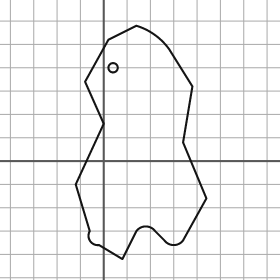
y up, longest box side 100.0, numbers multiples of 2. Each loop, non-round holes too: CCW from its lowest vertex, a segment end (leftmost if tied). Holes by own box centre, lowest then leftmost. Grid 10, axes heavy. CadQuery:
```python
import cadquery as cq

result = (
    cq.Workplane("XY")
    .moveTo(8.0, -42.0)
    .lineTo(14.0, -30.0)
    .threePointArc((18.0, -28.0), (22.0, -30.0))
    .lineTo(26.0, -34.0)
    .threePointArc((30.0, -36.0), (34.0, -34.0))
    .lineTo(44.0, -16.0)
    .lineTo(34.0, 8.0)
    .lineTo(38.0, 32.0)
    .lineTo(28.0, 48.0)
    .threePointArc((22.0, 54.0), (14.0, 58.0))
    .lineTo(2.0, 52.0)
    .lineTo(-8.0, 34.0)
    .lineTo(0.0, 16.0)
    .lineTo(-12.0, -10.0)
    .lineTo(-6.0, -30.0)
    .threePointArc((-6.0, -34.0), (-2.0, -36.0))
    .close()
    .moveTo(4.0, 40.0)
    .circle(2.0)
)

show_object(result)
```